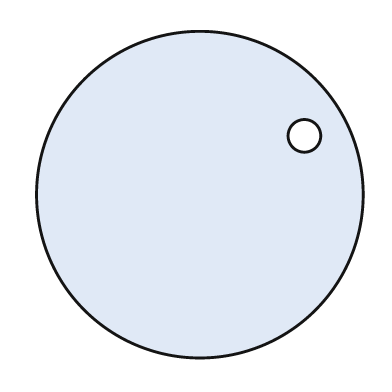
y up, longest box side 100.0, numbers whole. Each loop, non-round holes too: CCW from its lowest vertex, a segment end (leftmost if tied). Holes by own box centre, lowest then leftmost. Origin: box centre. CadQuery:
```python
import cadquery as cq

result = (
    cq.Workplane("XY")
    .moveTo(0.0, 0.0)
    .circle(50.0)
    .moveTo(32.0, 18.0)
    .circle(5.0)
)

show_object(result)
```